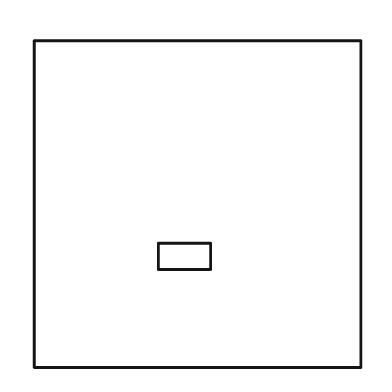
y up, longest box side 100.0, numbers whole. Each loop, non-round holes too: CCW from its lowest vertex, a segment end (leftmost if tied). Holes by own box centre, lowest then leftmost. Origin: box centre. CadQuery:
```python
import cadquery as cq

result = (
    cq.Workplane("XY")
    .moveTo(-50.0, -50.0)
    .lineTo(50.0, -50.0)
    .lineTo(50.0, 50.0)
    .lineTo(-50.0, 50.0)
    .close()
    .moveTo(-12.0, -20.0)
    .lineTo(4.0, -20.0)
    .lineTo(4.0, -12.0)
    .lineTo(-12.0, -12.0)
    .close()
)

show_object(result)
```